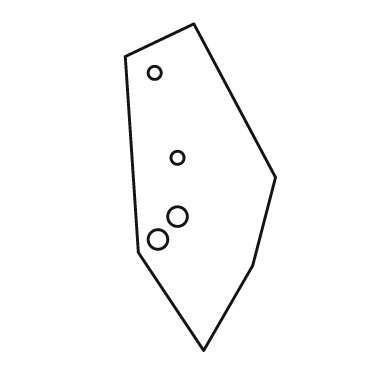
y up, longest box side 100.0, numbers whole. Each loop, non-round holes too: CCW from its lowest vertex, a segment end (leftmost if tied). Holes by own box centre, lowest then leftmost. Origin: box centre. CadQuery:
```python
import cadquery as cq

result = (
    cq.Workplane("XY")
    .moveTo(1.0, -50.0)
    .lineTo(16.0, -24.0)
    .lineTo(23.0, 3.0)
    .lineTo(-2.0, 50.0)
    .lineTo(-23.0, 40.0)
    .lineTo(-19.0, -20.0)
    .close()
    .moveTo(-13.0, -16.0)
    .circle(3.0)
    .moveTo(-7.0, -9.0)
    .circle(3.0)
    .moveTo(-7.0, 9.0)
    .circle(2.0)
    .moveTo(-14.0, 35.0)
    .circle(2.0)
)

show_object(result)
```